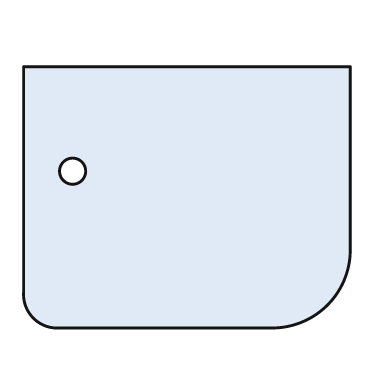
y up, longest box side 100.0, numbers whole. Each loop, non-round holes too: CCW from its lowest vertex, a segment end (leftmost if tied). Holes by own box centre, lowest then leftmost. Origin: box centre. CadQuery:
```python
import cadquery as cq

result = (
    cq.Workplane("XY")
    .moveTo(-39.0, -40.0)
    .lineTo(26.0, -40.0)
    .threePointArc((43.0, -33.0), (50.0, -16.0))
    .lineTo(50.0, 40.0)
    .lineTo(-50.0, 40.0)
    .lineTo(-50.0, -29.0)
    .threePointArc((-47.0, -37.0), (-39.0, -40.0))
    .close()
    .moveTo(-35.0, 8.0)
    .circle(4.0)
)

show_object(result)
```